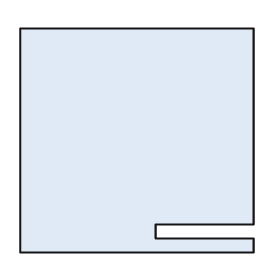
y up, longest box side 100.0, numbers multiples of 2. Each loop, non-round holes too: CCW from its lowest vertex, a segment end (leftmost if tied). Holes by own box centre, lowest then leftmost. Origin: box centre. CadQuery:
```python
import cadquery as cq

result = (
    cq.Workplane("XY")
    .moveTo(-50.0, -48.0)
    .lineTo(50.0, -48.0)
    .lineTo(50.0, -42.0)
    .lineTo(8.0, -42.0)
    .lineTo(8.0, -36.0)
    .lineTo(50.0, -36.0)
    .lineTo(50.0, 48.0)
    .lineTo(-50.0, 48.0)
    .close()
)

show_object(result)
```